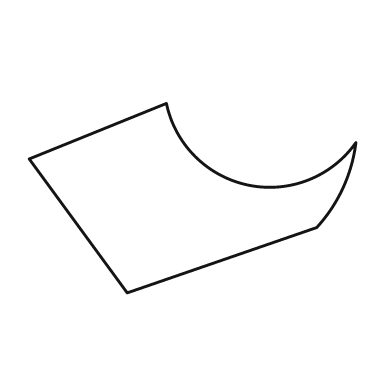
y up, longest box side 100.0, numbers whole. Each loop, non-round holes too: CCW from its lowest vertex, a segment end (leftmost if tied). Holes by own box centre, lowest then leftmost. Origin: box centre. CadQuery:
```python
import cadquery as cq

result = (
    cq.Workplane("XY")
    .moveTo(-20.0, -29.0)
    .lineTo(38.0, -9.0)
    .threePointArc((46.0, 3.0), (50.0, 17.0))
    .threePointArc((17.0, 4.0), (-8.0, 29.0))
    .lineTo(-50.0, 12.0)
    .close()
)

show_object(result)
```